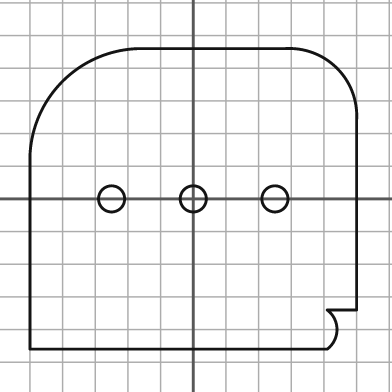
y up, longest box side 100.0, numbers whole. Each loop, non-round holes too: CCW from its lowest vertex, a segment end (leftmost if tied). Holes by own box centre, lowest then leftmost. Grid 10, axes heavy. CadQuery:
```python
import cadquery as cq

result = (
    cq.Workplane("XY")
    .moveTo(-50.0, -46.0)
    .lineTo(41.0, -46.0)
    .threePointArc((44.0, -40.0), (41.0, -34.0))
    .lineTo(50.0, -34.0)
    .lineTo(50.0, 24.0)
    .threePointArc((44.0, 40.0), (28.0, 46.0))
    .lineTo(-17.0, 46.0)
    .threePointArc((-40.0, 36.0), (-50.0, 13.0))
    .close()
    .moveTo(-25.0, 0.0)
    .circle(4.0)
    .moveTo(0.0, 0.0)
    .circle(4.0)
    .moveTo(25.0, 0.0)
    .circle(4.0)
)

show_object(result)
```